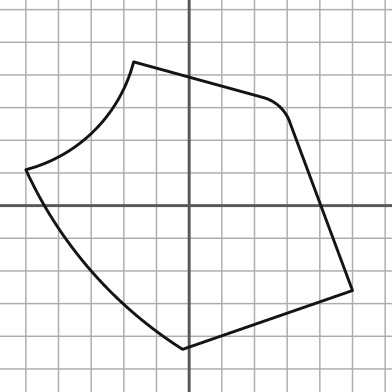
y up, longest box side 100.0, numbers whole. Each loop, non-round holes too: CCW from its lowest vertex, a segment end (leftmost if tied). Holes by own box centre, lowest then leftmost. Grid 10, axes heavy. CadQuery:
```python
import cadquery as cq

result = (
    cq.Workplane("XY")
    .moveTo(-2.0, -44.0)
    .lineTo(50.0, -26.0)
    .lineTo(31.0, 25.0)
    .threePointArc((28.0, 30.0), (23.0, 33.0))
    .lineTo(-17.0, 44.0)
    .threePointArc((-29.0, 23.0), (-50.0, 11.0))
    .threePointArc((-30.0, -20.0), (-2.0, -44.0))
    .close()
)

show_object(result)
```